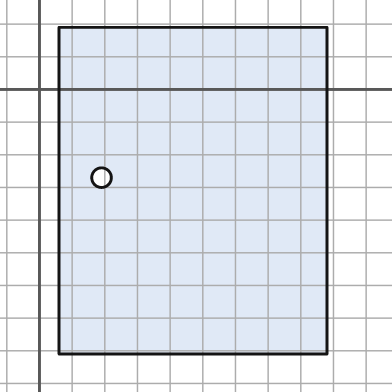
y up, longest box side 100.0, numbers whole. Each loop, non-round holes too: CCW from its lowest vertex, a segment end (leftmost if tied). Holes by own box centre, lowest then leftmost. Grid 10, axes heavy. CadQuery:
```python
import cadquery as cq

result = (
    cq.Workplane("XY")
    .moveTo(6.0, -81.0)
    .lineTo(88.0, -81.0)
    .lineTo(88.0, 19.0)
    .lineTo(6.0, 19.0)
    .close()
    .moveTo(19.0, -27.0)
    .circle(3.0)
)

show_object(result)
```